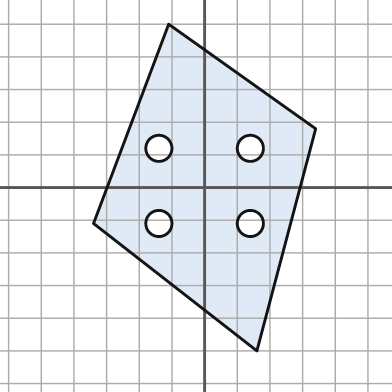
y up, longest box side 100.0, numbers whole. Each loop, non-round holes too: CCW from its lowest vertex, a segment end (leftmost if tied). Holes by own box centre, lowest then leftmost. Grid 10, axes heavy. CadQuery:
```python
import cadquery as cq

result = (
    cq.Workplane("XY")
    .moveTo(16.0, -50.0)
    .lineTo(34.0, 18.0)
    .lineTo(-11.0, 50.0)
    .lineTo(-34.0, -11.0)
    .close()
    .moveTo(-14.0, -11.0)
    .circle(4.0)
    .moveTo(14.0, -11.0)
    .circle(4.0)
    .moveTo(-14.0, 12.0)
    .circle(4.0)
    .moveTo(14.0, 12.0)
    .circle(4.0)
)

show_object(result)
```